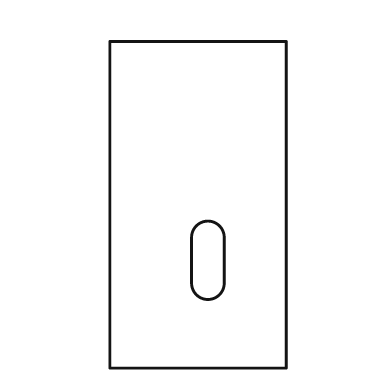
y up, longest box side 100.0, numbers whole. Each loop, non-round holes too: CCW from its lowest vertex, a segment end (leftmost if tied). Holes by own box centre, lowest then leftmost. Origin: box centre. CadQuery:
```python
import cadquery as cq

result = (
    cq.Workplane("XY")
    .moveTo(-27.0, -50.0)
    .lineTo(27.0, -50.0)
    .lineTo(27.0, 50.0)
    .lineTo(-27.0, 50.0)
    .close()
    .moveTo(-2.0, -24.0)
    .threePointArc((3.0, -29.0), (8.0, -24.0))
    .lineTo(8.0, -10.0)
    .threePointArc((3.0, -5.0), (-2.0, -10.0))
    .close()
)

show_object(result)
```